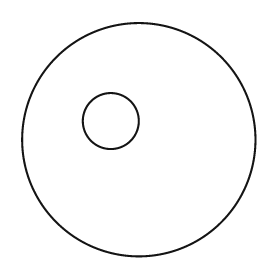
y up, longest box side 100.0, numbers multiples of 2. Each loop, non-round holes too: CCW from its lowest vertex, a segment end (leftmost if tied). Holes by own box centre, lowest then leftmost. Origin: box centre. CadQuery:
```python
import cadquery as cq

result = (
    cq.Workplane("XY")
    .moveTo(0.0, 0.0)
    .circle(50.0)
    .moveTo(-12.0, 8.0)
    .circle(12.0)
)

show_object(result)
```